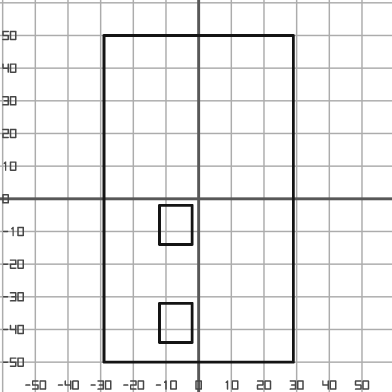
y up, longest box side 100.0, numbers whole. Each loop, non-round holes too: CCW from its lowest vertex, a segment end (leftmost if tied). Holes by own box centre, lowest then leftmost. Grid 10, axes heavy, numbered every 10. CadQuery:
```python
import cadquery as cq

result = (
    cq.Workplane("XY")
    .moveTo(-29.0, -50.0)
    .lineTo(29.0, -50.0)
    .lineTo(29.0, 50.0)
    .lineTo(-29.0, 50.0)
    .close()
    .moveTo(-12.0, -44.0)
    .lineTo(-2.0, -44.0)
    .lineTo(-2.0, -32.0)
    .lineTo(-12.0, -32.0)
    .close()
    .moveTo(-12.0, -14.0)
    .lineTo(-2.0, -14.0)
    .lineTo(-2.0, -2.0)
    .lineTo(-12.0, -2.0)
    .close()
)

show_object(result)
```